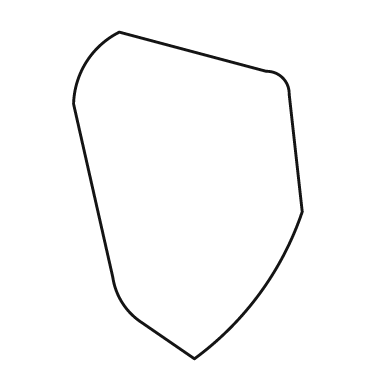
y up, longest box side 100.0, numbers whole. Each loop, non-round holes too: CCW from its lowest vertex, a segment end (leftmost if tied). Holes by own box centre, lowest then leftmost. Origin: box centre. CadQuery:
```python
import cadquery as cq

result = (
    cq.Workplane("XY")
    .moveTo(2.0, -50.0)
    .threePointArc((22.0, -30.0), (35.0, -5.0))
    .lineTo(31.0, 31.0)
    .threePointArc((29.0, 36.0), (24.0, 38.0))
    .lineTo(-21.0, 50.0)
    .threePointArc((-31.0, 41.0), (-35.0, 28.0))
    .lineTo(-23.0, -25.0)
    .threePointArc((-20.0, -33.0), (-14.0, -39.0))
    .close()
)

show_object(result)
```